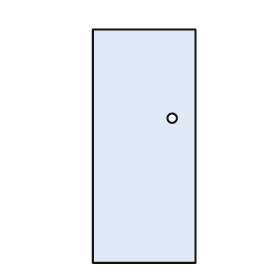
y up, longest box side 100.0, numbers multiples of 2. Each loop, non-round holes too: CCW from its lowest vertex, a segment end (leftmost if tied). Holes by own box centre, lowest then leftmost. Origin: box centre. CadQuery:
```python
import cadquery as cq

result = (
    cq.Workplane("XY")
    .moveTo(-22.0, -50.0)
    .lineTo(22.0, -50.0)
    .lineTo(22.0, 50.0)
    .lineTo(-22.0, 50.0)
    .close()
    .moveTo(12.0, 12.0)
    .circle(2.0)
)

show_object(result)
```